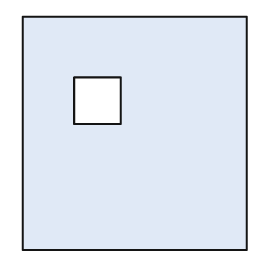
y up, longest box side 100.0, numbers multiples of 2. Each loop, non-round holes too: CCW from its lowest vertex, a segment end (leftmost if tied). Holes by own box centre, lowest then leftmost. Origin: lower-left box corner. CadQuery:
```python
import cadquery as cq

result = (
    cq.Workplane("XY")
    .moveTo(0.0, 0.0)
    .lineTo(96.0, 0.0)
    .lineTo(96.0, 100.0)
    .lineTo(0.0, 100.0)
    .close()
    .moveTo(22.0, 54.0)
    .lineTo(42.0, 54.0)
    .lineTo(42.0, 74.0)
    .lineTo(22.0, 74.0)
    .close()
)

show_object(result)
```